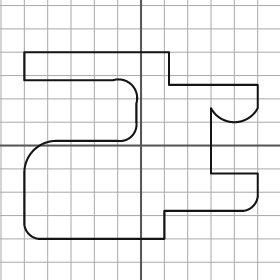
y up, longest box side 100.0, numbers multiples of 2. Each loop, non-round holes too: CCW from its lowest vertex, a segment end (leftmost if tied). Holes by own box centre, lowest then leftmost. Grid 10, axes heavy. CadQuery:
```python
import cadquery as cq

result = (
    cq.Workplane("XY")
    .moveTo(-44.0, -40.0)
    .lineTo(10.0, -40.0)
    .lineTo(10.0, -28.0)
    .lineTo(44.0, -28.0)
    .threePointArc((48.0, -26.0), (50.0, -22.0))
    .lineTo(50.0, -12.0)
    .lineTo(30.0, -12.0)
    .lineTo(30.0, 16.0)
    .threePointArc((40.0, 10.0), (50.0, 16.0))
    .lineTo(50.0, 26.0)
    .lineTo(12.0, 26.0)
    .lineTo(12.0, 40.0)
    .lineTo(-50.0, 40.0)
    .lineTo(-50.0, 28.0)
    .lineTo(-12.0, 28.0)
    .threePointArc((-4.0, 26.0), (-2.0, 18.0))
    .lineTo(-2.0, 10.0)
    .threePointArc((-4.0, 4.0), (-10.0, 2.0))
    .lineTo(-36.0, 2.0)
    .threePointArc((-46.0, -2.0), (-50.0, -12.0))
    .lineTo(-50.0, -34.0)
    .threePointArc((-48.0, -38.0), (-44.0, -40.0))
    .close()
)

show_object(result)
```